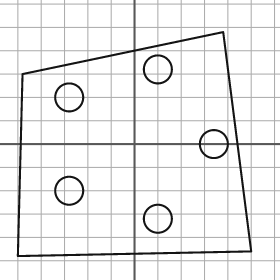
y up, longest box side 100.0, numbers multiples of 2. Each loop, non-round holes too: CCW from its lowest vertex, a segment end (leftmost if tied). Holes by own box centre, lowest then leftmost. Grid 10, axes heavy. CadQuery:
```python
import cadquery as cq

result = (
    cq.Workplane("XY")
    .moveTo(-50.0, -48.0)
    .lineTo(50.0, -46.0)
    .lineTo(38.0, 48.0)
    .lineTo(-48.0, 30.0)
    .close()
    .moveTo(10.0, -32.0)
    .circle(6.0)
    .moveTo(-28.0, -20.0)
    .circle(6.0)
    .moveTo(34.0, 0.0)
    .circle(6.0)
    .moveTo(-28.0, 20.0)
    .circle(6.0)
    .moveTo(10.0, 32.0)
    .circle(6.0)
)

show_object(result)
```